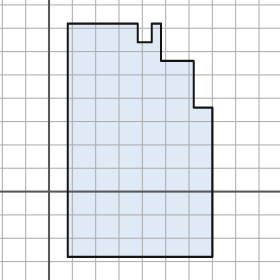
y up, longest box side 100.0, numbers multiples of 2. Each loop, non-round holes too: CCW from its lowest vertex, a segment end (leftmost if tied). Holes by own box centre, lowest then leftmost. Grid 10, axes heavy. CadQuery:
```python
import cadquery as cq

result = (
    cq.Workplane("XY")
    .moveTo(8.0, -28.0)
    .lineTo(70.0, -28.0)
    .lineTo(70.0, 36.0)
    .lineTo(62.0, 36.0)
    .lineTo(62.0, 56.0)
    .lineTo(48.0, 56.0)
    .lineTo(48.0, 72.0)
    .lineTo(44.0, 72.0)
    .lineTo(44.0, 64.0)
    .lineTo(38.0, 64.0)
    .lineTo(38.0, 72.0)
    .lineTo(8.0, 72.0)
    .close()
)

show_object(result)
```